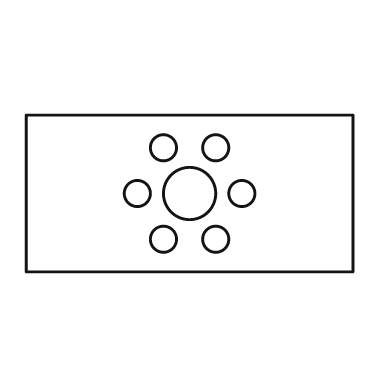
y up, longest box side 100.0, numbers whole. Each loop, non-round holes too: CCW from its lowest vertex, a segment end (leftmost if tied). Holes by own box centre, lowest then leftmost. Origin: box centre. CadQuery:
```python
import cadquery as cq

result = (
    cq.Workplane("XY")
    .moveTo(-50.0, -24.0)
    .lineTo(50.0, -24.0)
    .lineTo(50.0, 24.0)
    .lineTo(-50.0, 24.0)
    .close()
    .moveTo(-8.0, -14.0)
    .circle(4.0)
    .moveTo(8.0, -14.0)
    .circle(4.0)
    .moveTo(-16.0, 0.0)
    .circle(4.0)
    .moveTo(0.0, 0.0)
    .circle(8.0)
    .moveTo(16.0, 0.0)
    .circle(4.0)
    .moveTo(-8.0, 14.0)
    .circle(4.0)
    .moveTo(8.0, 14.0)
    .circle(4.0)
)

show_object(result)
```